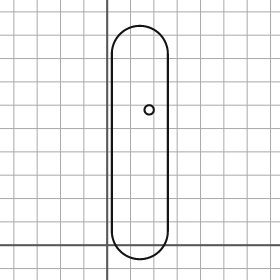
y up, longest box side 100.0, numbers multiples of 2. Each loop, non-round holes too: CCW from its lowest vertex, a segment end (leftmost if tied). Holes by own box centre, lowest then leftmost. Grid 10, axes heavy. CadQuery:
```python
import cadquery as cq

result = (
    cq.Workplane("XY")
    .moveTo(2.0, 6.0)
    .threePointArc((14.0, -6.0), (26.0, 6.0))
    .lineTo(26.0, 82.0)
    .threePointArc((14.0, 94.0), (2.0, 82.0))
    .close()
    .moveTo(18.0, 58.0)
    .circle(2.0)
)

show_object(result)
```